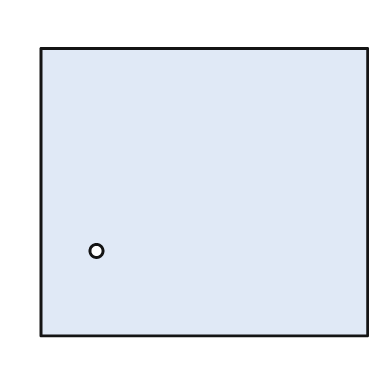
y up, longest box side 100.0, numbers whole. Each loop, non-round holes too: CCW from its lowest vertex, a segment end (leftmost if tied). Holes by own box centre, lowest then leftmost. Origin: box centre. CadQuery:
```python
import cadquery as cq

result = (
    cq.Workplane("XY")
    .moveTo(-50.0, -44.0)
    .lineTo(50.0, -44.0)
    .lineTo(50.0, 44.0)
    .lineTo(-50.0, 44.0)
    .close()
    .moveTo(-33.0, -18.0)
    .circle(2.0)
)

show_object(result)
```